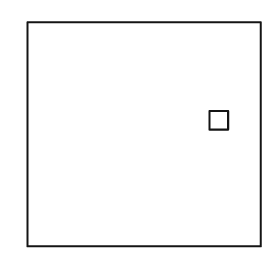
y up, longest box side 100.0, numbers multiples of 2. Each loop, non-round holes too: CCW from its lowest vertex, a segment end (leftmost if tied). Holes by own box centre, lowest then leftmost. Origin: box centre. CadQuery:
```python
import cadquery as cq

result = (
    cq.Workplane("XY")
    .moveTo(-50.0, -48.0)
    .lineTo(50.0, -48.0)
    .lineTo(50.0, 48.0)
    .lineTo(-50.0, 48.0)
    .close()
    .moveTo(28.0, 2.0)
    .lineTo(36.0, 2.0)
    .lineTo(36.0, 10.0)
    .lineTo(28.0, 10.0)
    .close()
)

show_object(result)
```